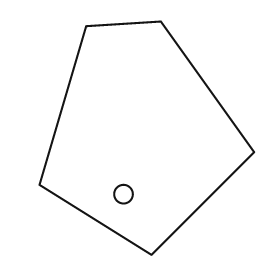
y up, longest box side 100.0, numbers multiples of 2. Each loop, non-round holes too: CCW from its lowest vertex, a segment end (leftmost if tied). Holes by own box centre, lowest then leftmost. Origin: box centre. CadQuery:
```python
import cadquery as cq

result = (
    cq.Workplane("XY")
    .moveTo(2.0, -50.0)
    .lineTo(46.0, -6.0)
    .lineTo(6.0, 50.0)
    .lineTo(-26.0, 48.0)
    .lineTo(-46.0, -20.0)
    .close()
    .moveTo(-10.0, -24.0)
    .circle(4.0)
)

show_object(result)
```